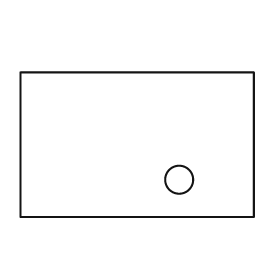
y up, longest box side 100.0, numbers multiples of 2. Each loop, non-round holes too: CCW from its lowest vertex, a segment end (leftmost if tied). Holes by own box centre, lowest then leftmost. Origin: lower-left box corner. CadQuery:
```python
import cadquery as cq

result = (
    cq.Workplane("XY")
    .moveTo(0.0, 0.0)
    .lineTo(100.0, 0.0)
    .lineTo(100.0, 62.0)
    .lineTo(0.0, 62.0)
    .close()
    .moveTo(68.0, 16.0)
    .circle(6.0)
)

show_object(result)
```